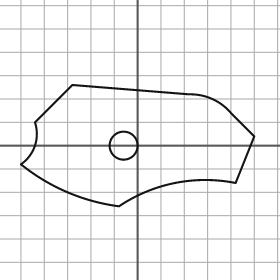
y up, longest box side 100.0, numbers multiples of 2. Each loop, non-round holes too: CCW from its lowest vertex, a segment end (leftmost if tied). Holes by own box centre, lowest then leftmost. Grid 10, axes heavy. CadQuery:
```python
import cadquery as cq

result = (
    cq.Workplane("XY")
    .moveTo(-8.0, -26.0)
    .threePointArc((16.0, -16.0), (42.0, -16.0))
    .lineTo(50.0, 4.0)
    .lineTo(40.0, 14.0)
    .threePointArc((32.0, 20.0), (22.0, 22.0))
    .lineTo(-28.0, 26.0)
    .lineTo(-44.0, 10.0)
    .threePointArc((-44.0, 0.0), (-50.0, -8.0))
    .threePointArc((-30.0, -20.0), (-8.0, -26.0))
    .close()
    .moveTo(-6.0, 0.0)
    .circle(6.0)
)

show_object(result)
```